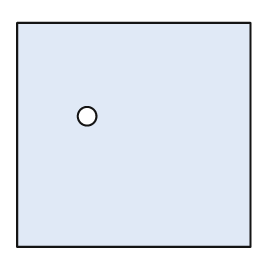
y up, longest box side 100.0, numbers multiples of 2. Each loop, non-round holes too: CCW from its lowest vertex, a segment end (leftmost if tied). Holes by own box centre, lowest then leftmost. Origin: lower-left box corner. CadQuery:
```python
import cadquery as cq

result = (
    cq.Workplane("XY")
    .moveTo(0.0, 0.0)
    .lineTo(100.0, 0.0)
    .lineTo(100.0, 96.0)
    .lineTo(0.0, 96.0)
    .close()
    .moveTo(30.0, 56.0)
    .circle(4.0)
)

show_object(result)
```